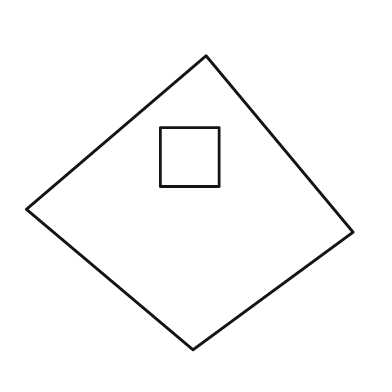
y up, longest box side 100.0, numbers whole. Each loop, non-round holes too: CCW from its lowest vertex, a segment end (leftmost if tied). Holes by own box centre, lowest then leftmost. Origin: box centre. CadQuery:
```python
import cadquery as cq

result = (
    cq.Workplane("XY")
    .moveTo(1.0, -45.0)
    .lineTo(50.0, -9.0)
    .lineTo(5.0, 45.0)
    .lineTo(-50.0, -2.0)
    .close()
    .moveTo(-9.0, 5.0)
    .lineTo(9.0, 5.0)
    .lineTo(9.0, 23.0)
    .lineTo(-9.0, 23.0)
    .close()
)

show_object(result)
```